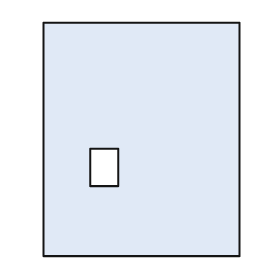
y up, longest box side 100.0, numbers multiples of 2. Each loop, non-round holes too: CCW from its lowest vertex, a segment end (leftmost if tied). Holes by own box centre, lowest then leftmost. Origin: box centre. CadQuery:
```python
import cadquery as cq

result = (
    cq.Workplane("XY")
    .moveTo(-42.0, -50.0)
    .lineTo(42.0, -50.0)
    .lineTo(42.0, 50.0)
    .lineTo(-42.0, 50.0)
    .close()
    .moveTo(-22.0, -20.0)
    .lineTo(-10.0, -20.0)
    .lineTo(-10.0, -4.0)
    .lineTo(-22.0, -4.0)
    .close()
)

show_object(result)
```